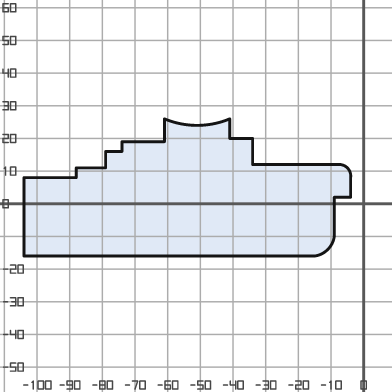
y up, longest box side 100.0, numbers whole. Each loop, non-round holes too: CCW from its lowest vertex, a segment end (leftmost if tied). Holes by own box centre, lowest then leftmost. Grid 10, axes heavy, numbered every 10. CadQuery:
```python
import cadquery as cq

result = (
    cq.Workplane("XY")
    .moveTo(-104.0, -16.0)
    .lineTo(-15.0, -16.0)
    .threePointArc((-11.0, -14.0), (-9.0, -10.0))
    .lineTo(-9.0, 2.0)
    .lineTo(-4.0, 2.0)
    .lineTo(-4.0, 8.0)
    .threePointArc((-5.0, 11.0), (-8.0, 12.0))
    .lineTo(-34.0, 12.0)
    .lineTo(-34.0, 20.0)
    .lineTo(-41.0, 20.0)
    .lineTo(-41.0, 26.0)
    .threePointArc((-51.0, 24.0), (-61.0, 26.0))
    .lineTo(-61.0, 19.0)
    .lineTo(-74.0, 19.0)
    .lineTo(-74.0, 16.0)
    .lineTo(-79.0, 16.0)
    .lineTo(-79.0, 11.0)
    .lineTo(-88.0, 11.0)
    .lineTo(-88.0, 8.0)
    .lineTo(-104.0, 8.0)
    .close()
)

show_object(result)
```